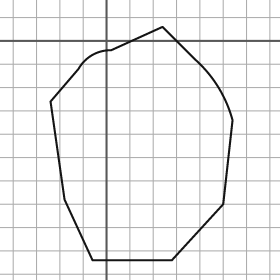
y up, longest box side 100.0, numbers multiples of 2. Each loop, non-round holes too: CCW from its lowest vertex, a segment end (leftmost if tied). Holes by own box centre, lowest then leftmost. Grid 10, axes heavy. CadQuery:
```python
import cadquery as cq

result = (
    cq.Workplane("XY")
    .moveTo(-6.0, -94.0)
    .lineTo(28.0, -94.0)
    .lineTo(50.0, -70.0)
    .lineTo(54.0, -34.0)
    .threePointArc((48.0, -20.0), (38.0, -8.0))
    .lineTo(24.0, 6.0)
    .lineTo(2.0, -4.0)
    .threePointArc((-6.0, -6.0), (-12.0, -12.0))
    .lineTo(-24.0, -26.0)
    .lineTo(-18.0, -68.0)
    .close()
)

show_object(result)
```